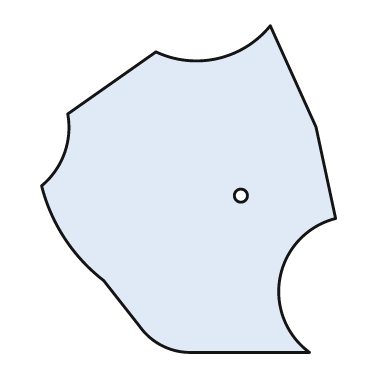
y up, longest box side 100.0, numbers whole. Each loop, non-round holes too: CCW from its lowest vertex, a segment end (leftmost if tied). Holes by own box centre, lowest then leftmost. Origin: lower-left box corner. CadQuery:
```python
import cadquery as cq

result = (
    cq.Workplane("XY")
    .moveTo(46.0, 0.0)
    .lineTo(82.0, 0.0)
    .threePointArc((73.0, 23.0), (90.0, 41.0))
    .lineTo(84.0, 69.0)
    .lineTo(70.0, 100.0)
    .threePointArc((54.0, 90.0), (35.0, 92.0))
    .lineTo(8.0, 73.0)
    .threePointArc((7.0, 61.0), (0.0, 51.0))
    .threePointArc((7.0, 35.0), (19.0, 22.0))
    .lineTo(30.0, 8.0)
    .threePointArc((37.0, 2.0), (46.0, 0.0))
    .close()
    .moveTo(61.0, 48.0)
    .circle(2.0)
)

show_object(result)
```